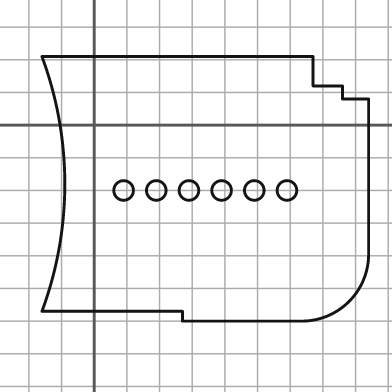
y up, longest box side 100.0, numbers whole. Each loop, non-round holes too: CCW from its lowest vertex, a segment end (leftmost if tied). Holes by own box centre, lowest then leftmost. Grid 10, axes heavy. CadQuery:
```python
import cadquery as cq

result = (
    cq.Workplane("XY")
    .moveTo(27.0, -60.0)
    .lineTo(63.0, -60.0)
    .threePointArc((78.0, -54.0), (84.0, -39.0))
    .lineTo(84.0, 8.0)
    .lineTo(76.0, 8.0)
    .lineTo(76.0, 12.0)
    .lineTo(67.0, 12.0)
    .lineTo(67.0, 21.0)
    .lineTo(-16.0, 21.0)
    .threePointArc((-9.0, -18.0), (-16.0, -57.0))
    .lineTo(27.0, -57.0)
    .close()
    .moveTo(9.0, -20.0)
    .circle(3.0)
    .moveTo(19.0, -20.0)
    .circle(3.0)
    .moveTo(29.0, -20.0)
    .circle(3.0)
    .moveTo(39.0, -20.0)
    .circle(3.0)
    .moveTo(49.0, -20.0)
    .circle(3.0)
    .moveTo(59.0, -20.0)
    .circle(3.0)
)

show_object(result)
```